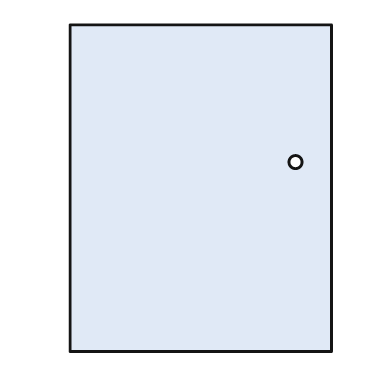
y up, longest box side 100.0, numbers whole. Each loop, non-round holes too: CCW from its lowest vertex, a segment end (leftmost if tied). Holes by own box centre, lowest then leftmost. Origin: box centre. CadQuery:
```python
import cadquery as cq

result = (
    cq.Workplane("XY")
    .moveTo(-40.0, -50.0)
    .lineTo(40.0, -50.0)
    .lineTo(40.0, 50.0)
    .lineTo(-40.0, 50.0)
    .close()
    .moveTo(29.0, 8.0)
    .circle(2.0)
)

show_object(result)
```